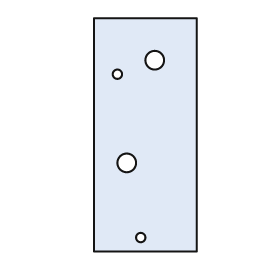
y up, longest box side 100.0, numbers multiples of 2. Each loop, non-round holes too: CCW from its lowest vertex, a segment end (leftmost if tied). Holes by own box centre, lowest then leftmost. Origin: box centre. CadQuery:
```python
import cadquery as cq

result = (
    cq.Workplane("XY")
    .moveTo(-22.0, -50.0)
    .lineTo(22.0, -50.0)
    .lineTo(22.0, 50.0)
    .lineTo(-22.0, 50.0)
    .close()
    .moveTo(-2.0, -44.0)
    .circle(2.0)
    .moveTo(-8.0, -12.0)
    .circle(4.0)
    .moveTo(-12.0, 26.0)
    .circle(2.0)
    .moveTo(4.0, 32.0)
    .circle(4.0)
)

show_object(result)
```